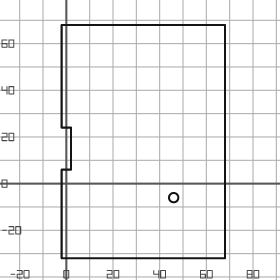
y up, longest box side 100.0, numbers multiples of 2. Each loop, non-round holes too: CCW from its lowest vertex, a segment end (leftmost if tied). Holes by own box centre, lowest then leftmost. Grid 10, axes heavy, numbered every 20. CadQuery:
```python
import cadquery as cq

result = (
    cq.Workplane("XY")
    .moveTo(-2.0, -32.0)
    .lineTo(68.0, -32.0)
    .lineTo(68.0, 68.0)
    .lineTo(-2.0, 68.0)
    .lineTo(-2.0, 24.0)
    .lineTo(2.0, 24.0)
    .lineTo(2.0, 6.0)
    .lineTo(-2.0, 6.0)
    .close()
    .moveTo(46.0, -6.0)
    .circle(2.0)
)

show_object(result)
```